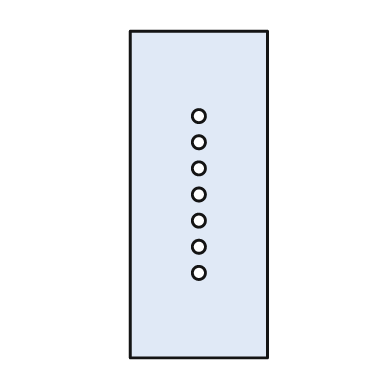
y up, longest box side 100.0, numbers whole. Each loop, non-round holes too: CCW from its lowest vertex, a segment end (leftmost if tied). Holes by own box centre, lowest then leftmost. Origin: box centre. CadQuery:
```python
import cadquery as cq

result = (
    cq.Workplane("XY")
    .moveTo(-21.0, -50.0)
    .lineTo(21.0, -50.0)
    .lineTo(21.0, 50.0)
    .lineTo(-21.0, 50.0)
    .close()
    .moveTo(0.0, -24.0)
    .circle(2.0)
    .moveTo(0.0, -16.0)
    .circle(2.0)
    .moveTo(0.0, -8.0)
    .circle(2.0)
    .moveTo(0.0, 0.0)
    .circle(2.0)
    .moveTo(0.0, 8.0)
    .circle(2.0)
    .moveTo(0.0, 16.0)
    .circle(2.0)
    .moveTo(0.0, 24.0)
    .circle(2.0)
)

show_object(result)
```